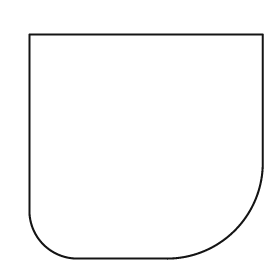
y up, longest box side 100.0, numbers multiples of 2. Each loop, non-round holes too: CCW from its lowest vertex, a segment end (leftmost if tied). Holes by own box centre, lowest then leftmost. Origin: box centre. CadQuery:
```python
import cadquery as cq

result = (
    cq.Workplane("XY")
    .moveTo(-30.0, -48.0)
    .lineTo(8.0, -48.0)
    .threePointArc((38.0, -36.0), (50.0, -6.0))
    .lineTo(50.0, 48.0)
    .lineTo(-50.0, 48.0)
    .lineTo(-50.0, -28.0)
    .threePointArc((-44.0, -42.0), (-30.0, -48.0))
    .close()
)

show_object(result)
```